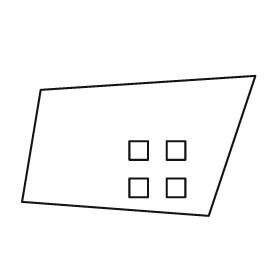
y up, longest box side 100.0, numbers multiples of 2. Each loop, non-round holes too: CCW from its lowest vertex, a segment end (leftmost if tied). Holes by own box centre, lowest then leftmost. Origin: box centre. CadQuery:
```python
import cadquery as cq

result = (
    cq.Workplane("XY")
    .moveTo(30.0, -30.0)
    .lineTo(50.0, 30.0)
    .lineTo(-42.0, 24.0)
    .lineTo(-50.0, -24.0)
    .close()
    .moveTo(-4.0, -22.0)
    .lineTo(4.0, -22.0)
    .lineTo(4.0, -14.0)
    .lineTo(-4.0, -14.0)
    .close()
    .moveTo(12.0, -22.0)
    .lineTo(20.0, -22.0)
    .lineTo(20.0, -14.0)
    .lineTo(12.0, -14.0)
    .close()
    .moveTo(-4.0, -6.0)
    .lineTo(4.0, -6.0)
    .lineTo(4.0, 2.0)
    .lineTo(-4.0, 2.0)
    .close()
    .moveTo(12.0, -6.0)
    .lineTo(20.0, -6.0)
    .lineTo(20.0, 2.0)
    .lineTo(12.0, 2.0)
    .close()
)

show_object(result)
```